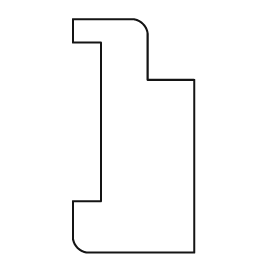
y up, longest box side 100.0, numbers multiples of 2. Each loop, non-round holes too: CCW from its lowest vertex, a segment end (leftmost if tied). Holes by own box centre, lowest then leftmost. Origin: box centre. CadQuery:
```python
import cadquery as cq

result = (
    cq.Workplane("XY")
    .moveTo(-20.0, -50.0)
    .lineTo(26.0, -50.0)
    .lineTo(26.0, 24.0)
    .lineTo(6.0, 24.0)
    .lineTo(6.0, 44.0)
    .threePointArc((4.0, 48.0), (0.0, 50.0))
    .lineTo(-26.0, 50.0)
    .lineTo(-26.0, 40.0)
    .lineTo(-14.0, 40.0)
    .lineTo(-14.0, -28.0)
    .lineTo(-26.0, -28.0)
    .lineTo(-26.0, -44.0)
    .threePointArc((-24.0, -48.0), (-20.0, -50.0))
    .close()
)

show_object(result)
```